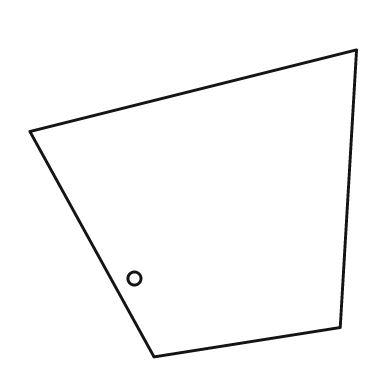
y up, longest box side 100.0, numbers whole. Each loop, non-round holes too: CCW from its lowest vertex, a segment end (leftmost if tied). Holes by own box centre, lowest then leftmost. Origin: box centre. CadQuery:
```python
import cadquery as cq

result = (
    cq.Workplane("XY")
    .moveTo(-12.0, -47.0)
    .lineTo(45.0, -38.0)
    .lineTo(50.0, 47.0)
    .lineTo(-50.0, 22.0)
    .close()
    .moveTo(-18.0, -23.0)
    .circle(2.0)
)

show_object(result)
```